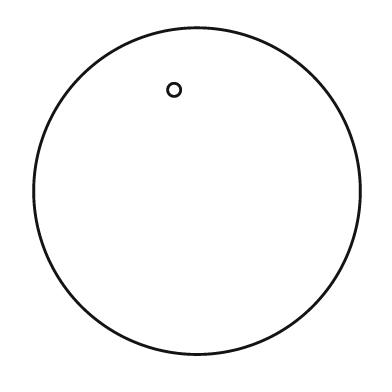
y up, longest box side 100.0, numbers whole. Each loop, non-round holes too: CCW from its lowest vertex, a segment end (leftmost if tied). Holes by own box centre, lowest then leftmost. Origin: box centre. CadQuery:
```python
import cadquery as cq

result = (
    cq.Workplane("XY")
    .moveTo(0.0, 0.0)
    .circle(50.0)
    .moveTo(-7.0, 31.0)
    .circle(2.0)
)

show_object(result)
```